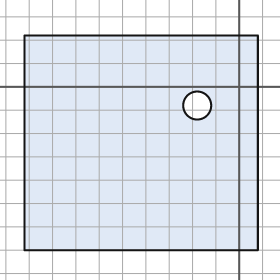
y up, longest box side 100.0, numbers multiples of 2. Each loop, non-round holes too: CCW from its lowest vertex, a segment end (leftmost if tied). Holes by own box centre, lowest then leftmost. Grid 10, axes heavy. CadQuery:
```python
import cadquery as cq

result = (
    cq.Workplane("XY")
    .moveTo(-92.0, -70.0)
    .lineTo(8.0, -70.0)
    .lineTo(8.0, 22.0)
    .lineTo(-92.0, 22.0)
    .close()
    .moveTo(-18.0, -8.0)
    .circle(6.0)
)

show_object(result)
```